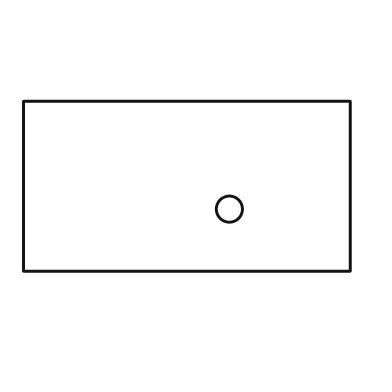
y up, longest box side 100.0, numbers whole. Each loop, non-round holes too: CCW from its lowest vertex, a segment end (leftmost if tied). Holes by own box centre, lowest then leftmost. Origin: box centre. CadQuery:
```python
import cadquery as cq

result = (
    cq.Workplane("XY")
    .moveTo(-50.0, -26.0)
    .lineTo(50.0, -26.0)
    .lineTo(50.0, 26.0)
    .lineTo(-50.0, 26.0)
    .close()
    .moveTo(13.0, -7.0)
    .circle(4.0)
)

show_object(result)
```